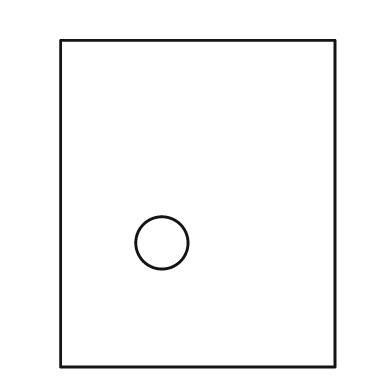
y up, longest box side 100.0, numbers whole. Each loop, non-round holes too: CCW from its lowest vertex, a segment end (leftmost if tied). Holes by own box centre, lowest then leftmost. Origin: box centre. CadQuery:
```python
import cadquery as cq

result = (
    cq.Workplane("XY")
    .moveTo(-42.0, -50.0)
    .lineTo(42.0, -50.0)
    .lineTo(42.0, 50.0)
    .lineTo(-42.0, 50.0)
    .close()
    .moveTo(-11.0, -12.0)
    .circle(8.0)
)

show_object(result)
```